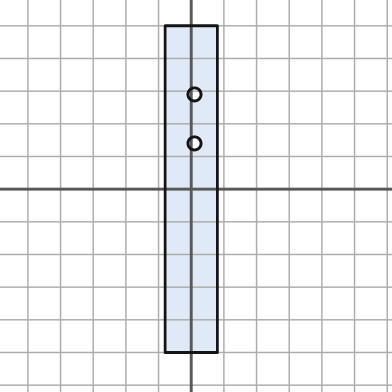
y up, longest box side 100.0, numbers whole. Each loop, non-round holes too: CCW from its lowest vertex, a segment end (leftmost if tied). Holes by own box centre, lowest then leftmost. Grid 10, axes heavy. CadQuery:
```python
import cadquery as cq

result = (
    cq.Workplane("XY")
    .moveTo(-8.0, -50.0)
    .lineTo(8.0, -50.0)
    .lineTo(8.0, 50.0)
    .lineTo(-8.0, 50.0)
    .close()
    .moveTo(1.0, 14.0)
    .circle(2.0)
    .moveTo(1.0, 29.0)
    .circle(2.0)
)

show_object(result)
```